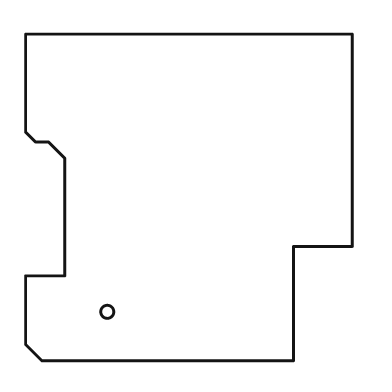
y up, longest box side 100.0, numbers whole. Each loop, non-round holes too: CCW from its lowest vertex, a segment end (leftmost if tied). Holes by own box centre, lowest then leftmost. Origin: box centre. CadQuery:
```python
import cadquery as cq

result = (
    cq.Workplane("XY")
    .moveTo(-45.0, -50.0)
    .lineTo(32.0, -50.0)
    .lineTo(32.0, -15.0)
    .lineTo(50.0, -15.0)
    .lineTo(50.0, 50.0)
    .lineTo(-50.0, 50.0)
    .lineTo(-50.0, 20.0)
    .lineTo(-47.0, 17.0)
    .lineTo(-43.0, 17.0)
    .lineTo(-38.0, 12.0)
    .lineTo(-38.0, -24.0)
    .lineTo(-50.0, -24.0)
    .lineTo(-50.0, -45.0)
    .close()
    .moveTo(-25.0, -35.0)
    .circle(2.0)
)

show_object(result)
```